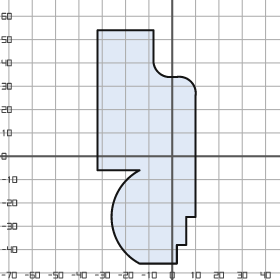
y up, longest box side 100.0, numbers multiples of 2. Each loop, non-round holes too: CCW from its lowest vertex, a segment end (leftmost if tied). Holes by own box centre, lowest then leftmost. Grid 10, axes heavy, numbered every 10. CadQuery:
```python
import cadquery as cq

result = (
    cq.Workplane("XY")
    .moveTo(-14.0, -46.0)
    .lineTo(2.0, -46.0)
    .lineTo(2.0, -38.0)
    .lineTo(6.0, -38.0)
    .lineTo(6.0, -26.0)
    .lineTo(10.0, -26.0)
    .lineTo(10.0, 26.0)
    .threePointArc((8.0, 32.0), (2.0, 34.0))
    .lineTo(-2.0, 34.0)
    .threePointArc((-6.0, 36.0), (-8.0, 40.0))
    .lineTo(-8.0, 54.0)
    .lineTo(-32.0, 54.0)
    .lineTo(-32.0, -6.0)
    .lineTo(-14.0, -6.0)
    .threePointArc((-26.0, -26.0), (-14.0, -46.0))
    .close()
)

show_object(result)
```